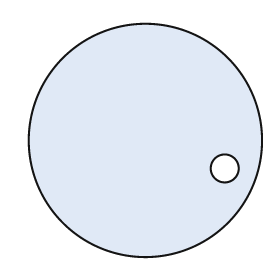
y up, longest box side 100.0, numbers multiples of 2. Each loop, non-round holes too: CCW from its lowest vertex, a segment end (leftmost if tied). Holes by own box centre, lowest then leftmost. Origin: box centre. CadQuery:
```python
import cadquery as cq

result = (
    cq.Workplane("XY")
    .moveTo(0.0, 0.0)
    .circle(50.0)
    .moveTo(34.0, -12.0)
    .circle(6.0)
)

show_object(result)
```